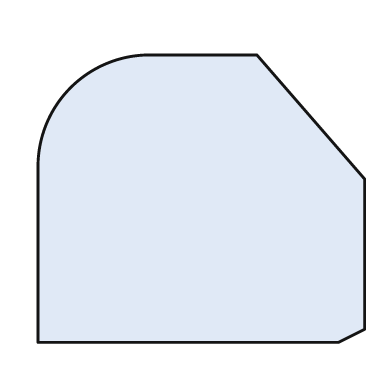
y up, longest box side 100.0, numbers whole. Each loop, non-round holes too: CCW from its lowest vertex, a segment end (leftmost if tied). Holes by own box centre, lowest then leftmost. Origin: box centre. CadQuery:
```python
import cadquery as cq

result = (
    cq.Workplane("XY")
    .moveTo(-50.0, -44.0)
    .lineTo(42.0, -44.0)
    .lineTo(50.0, -40.0)
    .lineTo(50.0, 6.0)
    .lineTo(17.0, 44.0)
    .lineTo(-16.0, 44.0)
    .threePointArc((-40.0, 34.0), (-50.0, 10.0))
    .close()
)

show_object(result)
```